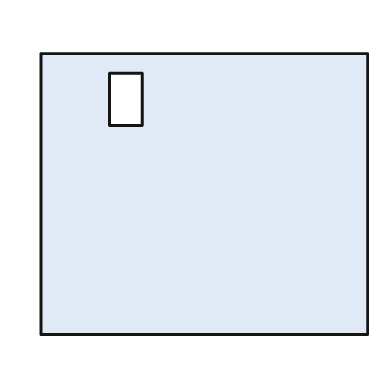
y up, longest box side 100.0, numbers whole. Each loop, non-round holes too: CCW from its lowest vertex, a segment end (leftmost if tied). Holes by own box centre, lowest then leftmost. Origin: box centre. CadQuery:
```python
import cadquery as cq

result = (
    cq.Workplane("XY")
    .moveTo(-50.0, -43.0)
    .lineTo(50.0, -43.0)
    .lineTo(50.0, 43.0)
    .lineTo(-50.0, 43.0)
    .close()
    .moveTo(-29.0, 21.0)
    .lineTo(-19.0, 21.0)
    .lineTo(-19.0, 37.0)
    .lineTo(-29.0, 37.0)
    .close()
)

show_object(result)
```